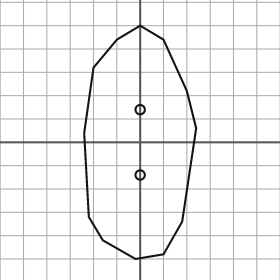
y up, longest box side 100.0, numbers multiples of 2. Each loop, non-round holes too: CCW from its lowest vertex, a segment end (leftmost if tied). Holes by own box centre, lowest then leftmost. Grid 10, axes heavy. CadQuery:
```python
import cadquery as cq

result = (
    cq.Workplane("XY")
    .moveTo(-2.0, -50.0)
    .lineTo(10.0, -48.0)
    .lineTo(18.0, -34.0)
    .lineTo(24.0, 6.0)
    .lineTo(20.0, 22.0)
    .lineTo(10.0, 44.0)
    .lineTo(0.0, 50.0)
    .lineTo(-10.0, 44.0)
    .lineTo(-20.0, 32.0)
    .lineTo(-24.0, 4.0)
    .lineTo(-22.0, -32.0)
    .lineTo(-16.0, -42.0)
    .close()
    .moveTo(0.0, -14.0)
    .circle(2.0)
    .moveTo(0.0, 14.0)
    .circle(2.0)
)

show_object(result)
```